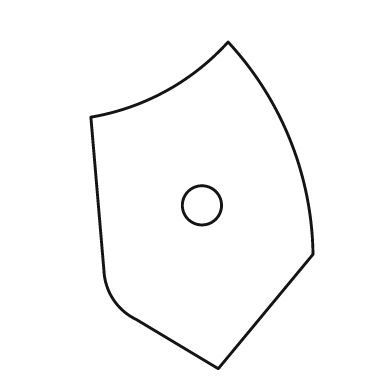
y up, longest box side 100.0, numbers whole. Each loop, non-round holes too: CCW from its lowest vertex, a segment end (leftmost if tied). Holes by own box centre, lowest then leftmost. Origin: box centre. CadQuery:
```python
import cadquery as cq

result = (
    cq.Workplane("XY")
    .moveTo(5.0, -50.0)
    .lineTo(34.0, -15.0)
    .threePointArc((27.0, 20.0), (8.0, 50.0))
    .threePointArc((-11.0, 35.0), (-34.0, 27.0))
    .lineTo(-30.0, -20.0)
    .threePointArc((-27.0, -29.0), (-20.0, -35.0))
    .close()
    .moveTo(0.0, 0.0)
    .circle(6.0)
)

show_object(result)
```